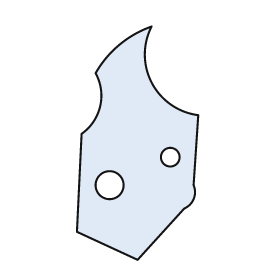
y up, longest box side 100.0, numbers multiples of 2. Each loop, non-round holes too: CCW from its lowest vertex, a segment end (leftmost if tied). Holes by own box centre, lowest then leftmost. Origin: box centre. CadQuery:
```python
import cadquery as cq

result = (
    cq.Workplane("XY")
    .moveTo(0.0, -50.0)
    .lineTo(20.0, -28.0)
    .threePointArc((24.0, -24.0), (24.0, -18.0))
    .lineTo(26.0, 12.0)
    .threePointArc((6.0, 26.0), (6.0, 50.0))
    .threePointArc((-8.0, 42.0), (-18.0, 30.0))
    .threePointArc((-16.0, 16.0), (-24.0, 4.0))
    .lineTo(-26.0, -38.0)
    .close()
    .moveTo(-12.0, -18.0)
    .circle(6.0)
    .moveTo(14.0, -6.0)
    .circle(4.0)
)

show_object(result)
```